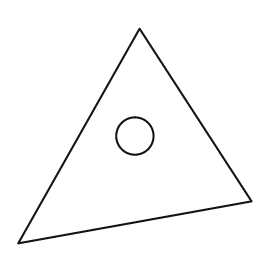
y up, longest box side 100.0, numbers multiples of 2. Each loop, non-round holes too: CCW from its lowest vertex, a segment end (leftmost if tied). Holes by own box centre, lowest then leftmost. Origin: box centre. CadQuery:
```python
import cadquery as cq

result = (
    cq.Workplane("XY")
    .moveTo(-50.0, -46.0)
    .lineTo(50.0, -28.0)
    .lineTo(2.0, 46.0)
    .close()
    .moveTo(0.0, 0.0)
    .circle(8.0)
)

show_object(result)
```